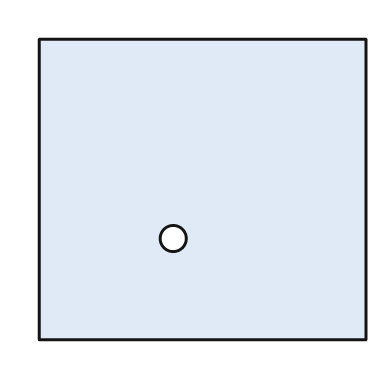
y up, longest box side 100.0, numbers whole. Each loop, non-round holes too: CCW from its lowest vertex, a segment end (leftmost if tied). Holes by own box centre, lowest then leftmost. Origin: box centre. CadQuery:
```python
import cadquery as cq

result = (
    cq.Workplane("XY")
    .moveTo(-50.0, -46.0)
    .lineTo(50.0, -46.0)
    .lineTo(50.0, 46.0)
    .lineTo(-50.0, 46.0)
    .close()
    .moveTo(-9.0, -15.0)
    .circle(4.0)
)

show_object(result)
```